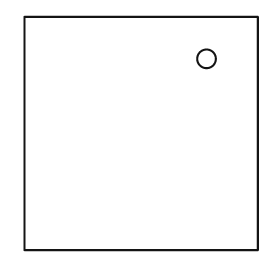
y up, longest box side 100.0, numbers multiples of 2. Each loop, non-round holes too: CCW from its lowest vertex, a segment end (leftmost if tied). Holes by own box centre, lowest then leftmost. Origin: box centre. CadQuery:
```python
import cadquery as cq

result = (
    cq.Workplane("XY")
    .moveTo(-50.0, -50.0)
    .lineTo(50.0, -50.0)
    .lineTo(50.0, 50.0)
    .lineTo(-50.0, 50.0)
    .close()
    .moveTo(28.0, 32.0)
    .circle(4.0)
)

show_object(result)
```